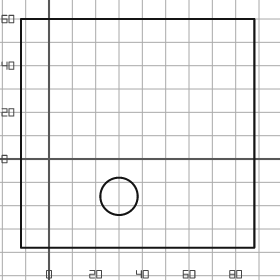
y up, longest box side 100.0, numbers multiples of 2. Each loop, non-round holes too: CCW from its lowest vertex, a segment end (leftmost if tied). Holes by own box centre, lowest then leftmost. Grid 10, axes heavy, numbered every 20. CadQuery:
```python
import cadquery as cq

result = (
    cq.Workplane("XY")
    .moveTo(-12.0, -38.0)
    .lineTo(88.0, -38.0)
    .lineTo(88.0, 60.0)
    .lineTo(-12.0, 60.0)
    .close()
    .moveTo(30.0, -16.0)
    .circle(8.0)
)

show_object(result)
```